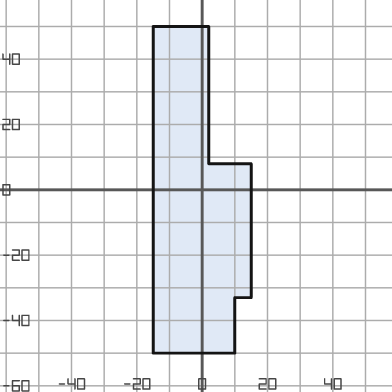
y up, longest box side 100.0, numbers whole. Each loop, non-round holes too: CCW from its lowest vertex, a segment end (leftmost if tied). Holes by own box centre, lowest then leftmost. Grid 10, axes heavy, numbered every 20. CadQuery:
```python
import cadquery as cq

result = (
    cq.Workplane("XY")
    .moveTo(-15.0, -50.0)
    .lineTo(10.0, -50.0)
    .lineTo(10.0, -33.0)
    .lineTo(15.0, -33.0)
    .lineTo(15.0, 8.0)
    .lineTo(2.0, 8.0)
    .lineTo(2.0, 50.0)
    .lineTo(-15.0, 50.0)
    .close()
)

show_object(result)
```